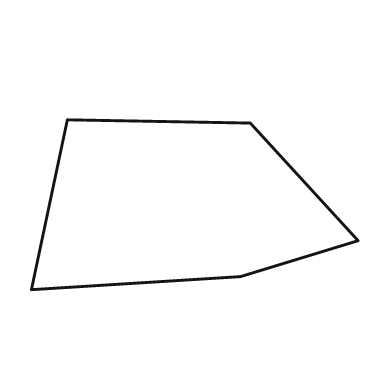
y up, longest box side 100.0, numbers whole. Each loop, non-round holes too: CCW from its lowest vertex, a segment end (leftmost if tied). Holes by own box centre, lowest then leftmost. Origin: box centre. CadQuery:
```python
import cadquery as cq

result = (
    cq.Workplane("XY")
    .moveTo(-50.0, -26.0)
    .lineTo(14.0, -22.0)
    .lineTo(50.0, -11.0)
    .lineTo(17.0, 25.0)
    .lineTo(-39.0, 26.0)
    .close()
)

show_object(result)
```